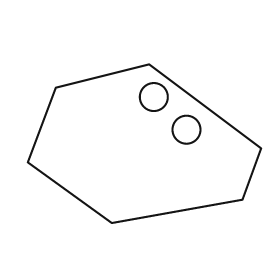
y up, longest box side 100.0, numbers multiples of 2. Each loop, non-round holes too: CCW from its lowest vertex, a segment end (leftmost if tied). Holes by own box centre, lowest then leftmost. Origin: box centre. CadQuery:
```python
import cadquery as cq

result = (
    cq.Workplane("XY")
    .moveTo(-14.0, -34.0)
    .lineTo(42.0, -24.0)
    .lineTo(50.0, -2.0)
    .lineTo(2.0, 34.0)
    .lineTo(-38.0, 24.0)
    .lineTo(-50.0, -8.0)
    .close()
    .moveTo(18.0, 6.0)
    .circle(6.0)
    .moveTo(4.0, 20.0)
    .circle(6.0)
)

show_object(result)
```